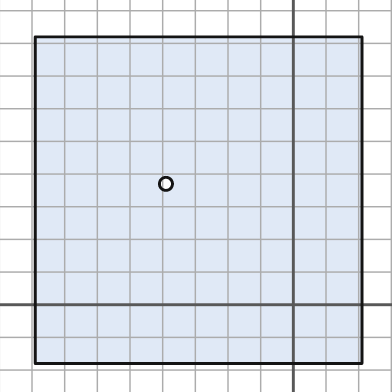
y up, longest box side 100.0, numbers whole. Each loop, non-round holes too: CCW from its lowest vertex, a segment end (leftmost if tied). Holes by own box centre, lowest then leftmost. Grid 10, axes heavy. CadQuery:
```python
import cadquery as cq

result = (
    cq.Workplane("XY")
    .moveTo(-79.0, -18.0)
    .lineTo(21.0, -18.0)
    .lineTo(21.0, 82.0)
    .lineTo(-79.0, 82.0)
    .close()
    .moveTo(-39.0, 37.0)
    .circle(2.0)
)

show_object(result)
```